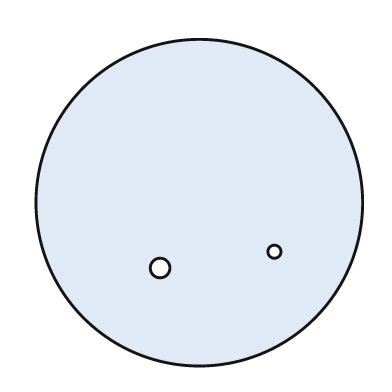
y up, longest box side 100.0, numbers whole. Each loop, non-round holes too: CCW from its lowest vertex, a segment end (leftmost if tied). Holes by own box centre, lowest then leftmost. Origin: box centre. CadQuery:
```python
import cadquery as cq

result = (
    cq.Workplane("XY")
    .moveTo(0.0, 0.0)
    .circle(50.0)
    .moveTo(-12.0, -20.0)
    .circle(3.0)
    .moveTo(23.0, -15.0)
    .circle(2.0)
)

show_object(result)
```